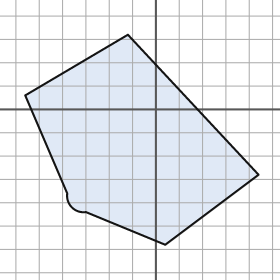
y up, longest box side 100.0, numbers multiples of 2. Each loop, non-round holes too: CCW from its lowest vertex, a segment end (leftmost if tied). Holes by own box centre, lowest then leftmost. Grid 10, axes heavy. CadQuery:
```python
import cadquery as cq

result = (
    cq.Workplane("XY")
    .moveTo(4.0, -58.0)
    .lineTo(44.0, -28.0)
    .lineTo(-12.0, 32.0)
    .lineTo(-56.0, 6.0)
    .lineTo(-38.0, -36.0)
    .threePointArc((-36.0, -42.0), (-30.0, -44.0))
    .close()
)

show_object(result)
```